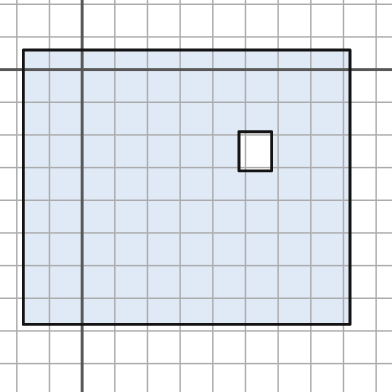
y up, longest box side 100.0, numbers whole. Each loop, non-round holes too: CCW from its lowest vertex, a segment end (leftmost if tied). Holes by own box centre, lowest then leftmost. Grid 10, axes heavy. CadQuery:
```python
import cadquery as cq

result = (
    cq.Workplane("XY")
    .moveTo(-18.0, -78.0)
    .lineTo(82.0, -78.0)
    .lineTo(82.0, 6.0)
    .lineTo(-18.0, 6.0)
    .close()
    .moveTo(48.0, -31.0)
    .lineTo(58.0, -31.0)
    .lineTo(58.0, -19.0)
    .lineTo(48.0, -19.0)
    .close()
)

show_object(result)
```